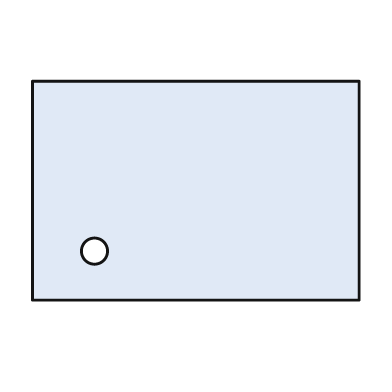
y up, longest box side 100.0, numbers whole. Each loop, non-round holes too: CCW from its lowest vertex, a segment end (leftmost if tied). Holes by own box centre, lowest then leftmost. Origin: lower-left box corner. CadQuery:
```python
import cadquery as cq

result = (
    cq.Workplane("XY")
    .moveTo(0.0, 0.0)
    .lineTo(100.0, 0.0)
    .lineTo(100.0, 67.0)
    .lineTo(0.0, 67.0)
    .close()
    .moveTo(19.0, 15.0)
    .circle(4.0)
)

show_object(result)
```